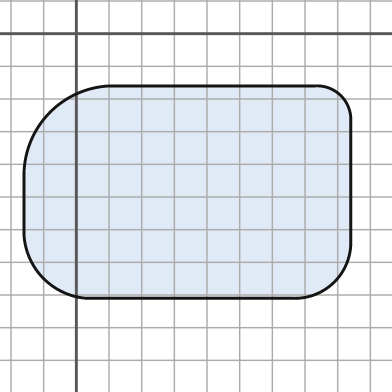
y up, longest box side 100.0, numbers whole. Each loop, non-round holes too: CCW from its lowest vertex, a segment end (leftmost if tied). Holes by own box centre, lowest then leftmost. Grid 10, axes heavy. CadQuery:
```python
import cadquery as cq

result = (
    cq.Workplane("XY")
    .moveTo(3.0, -81.0)
    .lineTo(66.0, -81.0)
    .threePointArc((79.0, -76.0), (84.0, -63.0))
    .lineTo(84.0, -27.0)
    .threePointArc((81.0, -19.0), (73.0, -16.0))
    .lineTo(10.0, -16.0)
    .threePointArc((-8.0, -24.0), (-16.0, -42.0))
    .lineTo(-16.0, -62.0)
    .threePointArc((-10.0, -75.0), (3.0, -81.0))
    .close()
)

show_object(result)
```